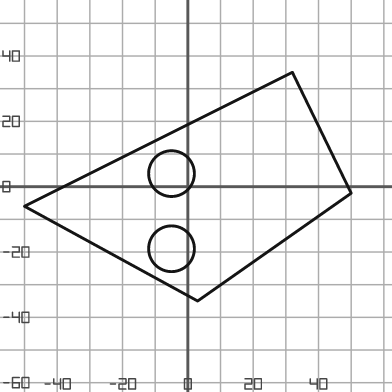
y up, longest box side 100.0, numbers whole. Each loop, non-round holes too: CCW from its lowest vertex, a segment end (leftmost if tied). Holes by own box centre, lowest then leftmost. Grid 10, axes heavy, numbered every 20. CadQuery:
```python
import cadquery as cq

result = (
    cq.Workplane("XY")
    .moveTo(3.0, -35.0)
    .lineTo(50.0, -2.0)
    .lineTo(32.0, 35.0)
    .lineTo(-50.0, -6.0)
    .close()
    .moveTo(-5.0, -19.0)
    .circle(7.0)
    .moveTo(-5.0, 4.0)
    .circle(7.0)
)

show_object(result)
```